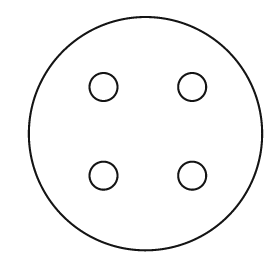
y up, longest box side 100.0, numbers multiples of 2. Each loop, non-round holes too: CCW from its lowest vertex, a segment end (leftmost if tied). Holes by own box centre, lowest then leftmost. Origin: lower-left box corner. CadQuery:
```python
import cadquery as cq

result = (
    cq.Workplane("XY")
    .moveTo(50.0, 50.0)
    .circle(50.0)
    .moveTo(32.0, 32.0)
    .circle(6.0)
    .moveTo(70.0, 32.0)
    .circle(6.0)
    .moveTo(32.0, 70.0)
    .circle(6.0)
    .moveTo(70.0, 70.0)
    .circle(6.0)
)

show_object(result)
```